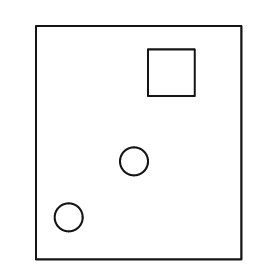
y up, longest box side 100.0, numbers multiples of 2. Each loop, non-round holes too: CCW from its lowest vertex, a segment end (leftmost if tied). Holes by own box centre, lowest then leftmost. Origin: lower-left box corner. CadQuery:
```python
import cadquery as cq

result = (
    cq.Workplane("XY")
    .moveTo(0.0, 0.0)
    .lineTo(88.0, 0.0)
    .lineTo(88.0, 100.0)
    .lineTo(0.0, 100.0)
    .close()
    .moveTo(14.0, 18.0)
    .circle(6.0)
    .moveTo(42.0, 42.0)
    .circle(6.0)
    .moveTo(48.0, 70.0)
    .lineTo(68.0, 70.0)
    .lineTo(68.0, 90.0)
    .lineTo(48.0, 90.0)
    .close()
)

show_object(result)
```